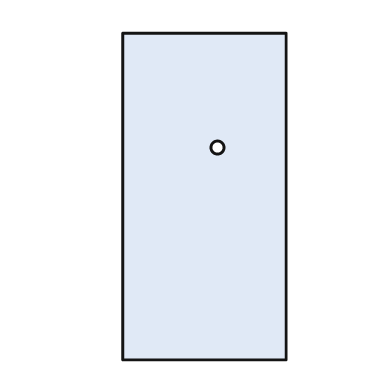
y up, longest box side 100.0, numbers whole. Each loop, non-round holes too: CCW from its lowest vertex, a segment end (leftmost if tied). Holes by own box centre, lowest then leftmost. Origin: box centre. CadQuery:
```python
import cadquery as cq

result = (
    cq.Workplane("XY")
    .moveTo(-25.0, -50.0)
    .lineTo(25.0, -50.0)
    .lineTo(25.0, 50.0)
    .lineTo(-25.0, 50.0)
    .close()
    .moveTo(4.0, 15.0)
    .circle(2.0)
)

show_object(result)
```